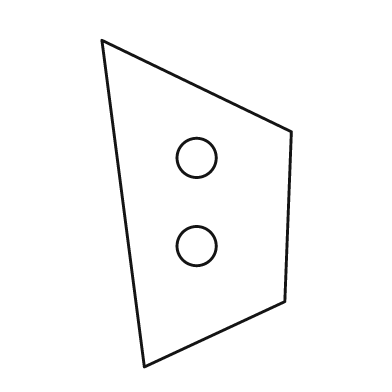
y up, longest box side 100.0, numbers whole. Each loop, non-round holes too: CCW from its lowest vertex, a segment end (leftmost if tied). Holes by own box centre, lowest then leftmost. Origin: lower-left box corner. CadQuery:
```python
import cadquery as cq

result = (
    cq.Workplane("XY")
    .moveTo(13.0, 0.0)
    .lineTo(56.0, 20.0)
    .lineTo(58.0, 72.0)
    .lineTo(0.0, 100.0)
    .close()
    .moveTo(29.0, 37.0)
    .circle(6.0)
    .moveTo(29.0, 64.0)
    .circle(6.0)
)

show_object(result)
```